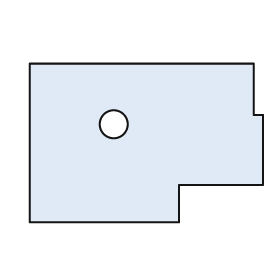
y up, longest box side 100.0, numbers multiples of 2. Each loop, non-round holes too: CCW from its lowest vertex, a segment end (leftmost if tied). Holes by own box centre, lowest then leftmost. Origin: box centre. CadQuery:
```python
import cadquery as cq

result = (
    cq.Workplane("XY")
    .moveTo(-50.0, -34.0)
    .lineTo(14.0, -34.0)
    .lineTo(14.0, -18.0)
    .lineTo(50.0, -18.0)
    .lineTo(50.0, 12.0)
    .lineTo(46.0, 12.0)
    .lineTo(46.0, 34.0)
    .lineTo(-50.0, 34.0)
    .close()
    .moveTo(-14.0, 8.0)
    .circle(6.0)
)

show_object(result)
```